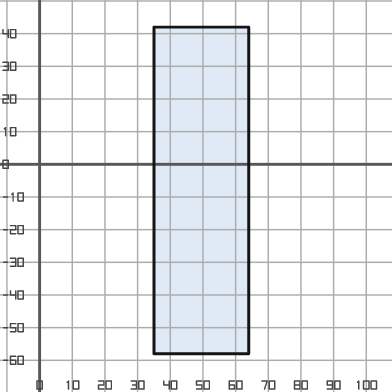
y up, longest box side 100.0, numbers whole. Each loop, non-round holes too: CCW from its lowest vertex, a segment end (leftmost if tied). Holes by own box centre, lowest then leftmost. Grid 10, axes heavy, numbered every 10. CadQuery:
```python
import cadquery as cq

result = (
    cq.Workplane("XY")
    .moveTo(35.0, -58.0)
    .lineTo(64.0, -58.0)
    .lineTo(64.0, 42.0)
    .lineTo(35.0, 42.0)
    .close()
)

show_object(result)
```